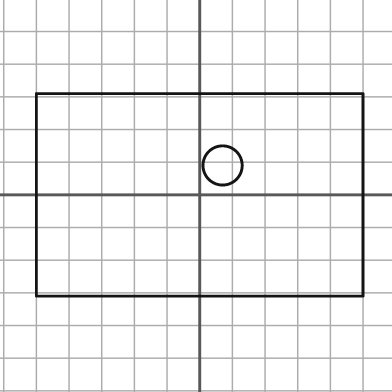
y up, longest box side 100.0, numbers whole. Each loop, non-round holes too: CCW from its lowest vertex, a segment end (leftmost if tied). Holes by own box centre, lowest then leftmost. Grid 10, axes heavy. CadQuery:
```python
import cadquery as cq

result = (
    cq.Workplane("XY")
    .moveTo(-50.0, -31.0)
    .lineTo(50.0, -31.0)
    .lineTo(50.0, 31.0)
    .lineTo(-50.0, 31.0)
    .close()
    .moveTo(7.0, 9.0)
    .circle(6.0)
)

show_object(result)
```